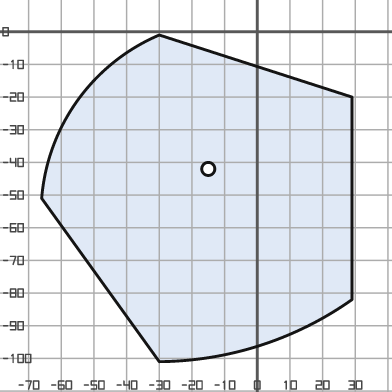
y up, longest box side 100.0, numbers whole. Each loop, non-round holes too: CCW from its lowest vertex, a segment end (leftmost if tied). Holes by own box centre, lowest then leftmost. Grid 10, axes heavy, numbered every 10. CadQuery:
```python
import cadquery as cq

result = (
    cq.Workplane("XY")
    .moveTo(-30.0, -101.0)
    .threePointArc((1.0, -96.0), (29.0, -82.0))
    .lineTo(29.0, -20.0)
    .lineTo(-30.0, -1.0)
    .threePointArc((-55.0, -21.0), (-66.0, -51.0))
    .close()
    .moveTo(-15.0, -42.0)
    .circle(2.0)
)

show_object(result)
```